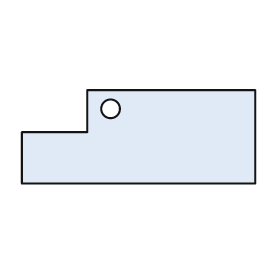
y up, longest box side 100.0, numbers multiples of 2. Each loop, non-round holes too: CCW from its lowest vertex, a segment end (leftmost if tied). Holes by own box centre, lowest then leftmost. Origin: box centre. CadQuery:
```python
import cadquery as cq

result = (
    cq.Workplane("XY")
    .moveTo(-50.0, -20.0)
    .lineTo(50.0, -20.0)
    .lineTo(50.0, 20.0)
    .lineTo(-22.0, 20.0)
    .lineTo(-22.0, 2.0)
    .lineTo(-50.0, 2.0)
    .close()
    .moveTo(-12.0, 12.0)
    .circle(4.0)
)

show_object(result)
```